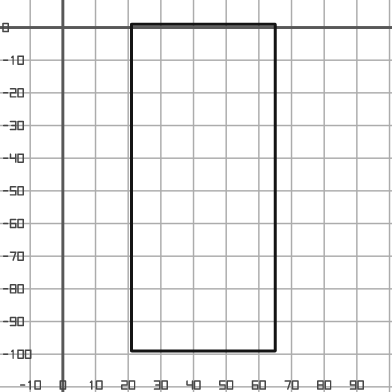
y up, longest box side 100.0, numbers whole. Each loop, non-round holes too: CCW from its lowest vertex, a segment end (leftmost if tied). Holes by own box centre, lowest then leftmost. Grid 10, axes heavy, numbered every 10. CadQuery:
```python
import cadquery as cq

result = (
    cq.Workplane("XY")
    .moveTo(21.0, -99.0)
    .lineTo(65.0, -99.0)
    .lineTo(65.0, 1.0)
    .lineTo(21.0, 1.0)
    .close()
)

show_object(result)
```